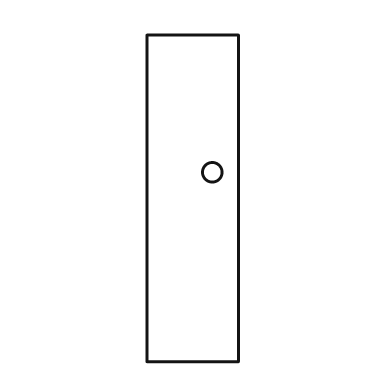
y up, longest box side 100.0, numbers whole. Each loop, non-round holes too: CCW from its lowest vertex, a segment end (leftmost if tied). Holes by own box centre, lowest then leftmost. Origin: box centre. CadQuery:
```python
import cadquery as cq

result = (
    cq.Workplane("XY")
    .moveTo(-14.0, -50.0)
    .lineTo(14.0, -50.0)
    .lineTo(14.0, 50.0)
    .lineTo(-14.0, 50.0)
    .close()
    .moveTo(6.0, 8.0)
    .circle(3.0)
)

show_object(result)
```